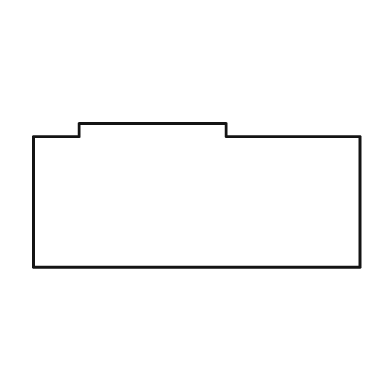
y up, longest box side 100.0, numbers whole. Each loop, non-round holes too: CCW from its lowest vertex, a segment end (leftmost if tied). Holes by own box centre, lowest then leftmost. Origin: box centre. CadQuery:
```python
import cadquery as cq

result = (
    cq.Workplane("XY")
    .moveTo(-50.0, -22.0)
    .lineTo(50.0, -22.0)
    .lineTo(50.0, 18.0)
    .lineTo(9.0, 18.0)
    .lineTo(9.0, 22.0)
    .lineTo(-36.0, 22.0)
    .lineTo(-36.0, 18.0)
    .lineTo(-50.0, 18.0)
    .close()
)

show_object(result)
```